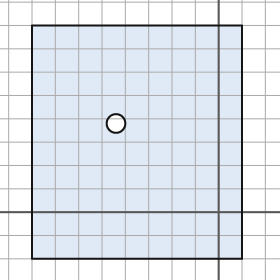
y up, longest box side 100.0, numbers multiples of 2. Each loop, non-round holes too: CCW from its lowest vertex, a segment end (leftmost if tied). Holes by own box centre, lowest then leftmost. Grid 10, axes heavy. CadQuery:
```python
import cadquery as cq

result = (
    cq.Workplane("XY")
    .moveTo(-80.0, -20.0)
    .lineTo(10.0, -20.0)
    .lineTo(10.0, 80.0)
    .lineTo(-80.0, 80.0)
    .close()
    .moveTo(-44.0, 38.0)
    .circle(4.0)
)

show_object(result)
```